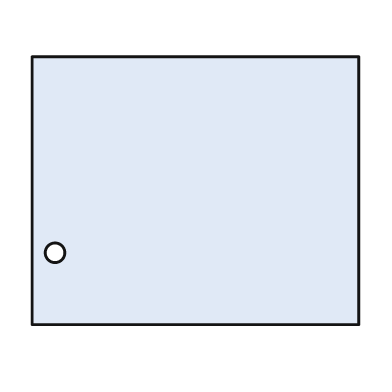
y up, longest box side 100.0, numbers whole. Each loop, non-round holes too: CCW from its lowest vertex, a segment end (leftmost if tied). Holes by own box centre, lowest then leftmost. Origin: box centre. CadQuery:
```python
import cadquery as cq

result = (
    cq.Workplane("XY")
    .moveTo(-50.0, -41.0)
    .lineTo(50.0, -41.0)
    .lineTo(50.0, 41.0)
    .lineTo(-50.0, 41.0)
    .close()
    .moveTo(-43.0, -19.0)
    .circle(3.0)
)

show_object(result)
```